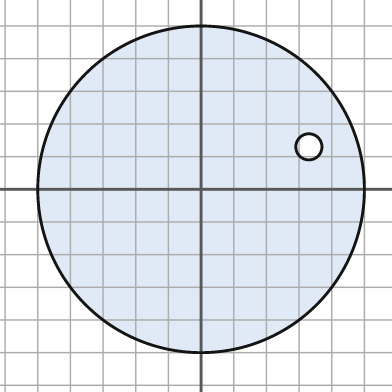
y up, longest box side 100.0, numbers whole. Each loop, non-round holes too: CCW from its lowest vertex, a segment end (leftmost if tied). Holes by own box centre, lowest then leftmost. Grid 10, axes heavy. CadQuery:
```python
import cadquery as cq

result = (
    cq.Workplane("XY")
    .moveTo(0.0, 0.0)
    .circle(50.0)
    .moveTo(33.0, 13.0)
    .circle(4.0)
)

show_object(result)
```